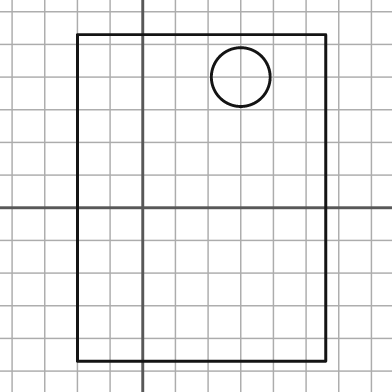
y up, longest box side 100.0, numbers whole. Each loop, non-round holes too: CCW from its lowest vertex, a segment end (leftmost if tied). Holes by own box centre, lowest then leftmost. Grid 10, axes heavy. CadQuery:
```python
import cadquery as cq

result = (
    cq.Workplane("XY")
    .moveTo(-20.0, -47.0)
    .lineTo(56.0, -47.0)
    .lineTo(56.0, 53.0)
    .lineTo(-20.0, 53.0)
    .close()
    .moveTo(30.0, 40.0)
    .circle(9.0)
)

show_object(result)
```